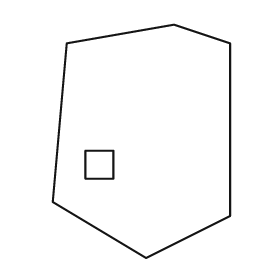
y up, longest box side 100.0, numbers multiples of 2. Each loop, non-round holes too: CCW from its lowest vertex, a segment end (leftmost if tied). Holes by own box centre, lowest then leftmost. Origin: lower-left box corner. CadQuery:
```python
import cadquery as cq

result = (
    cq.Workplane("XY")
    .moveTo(40.0, 0.0)
    .lineTo(76.0, 18.0)
    .lineTo(76.0, 92.0)
    .lineTo(52.0, 100.0)
    .lineTo(6.0, 92.0)
    .lineTo(0.0, 24.0)
    .close()
    .moveTo(14.0, 34.0)
    .lineTo(26.0, 34.0)
    .lineTo(26.0, 46.0)
    .lineTo(14.0, 46.0)
    .close()
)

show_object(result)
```